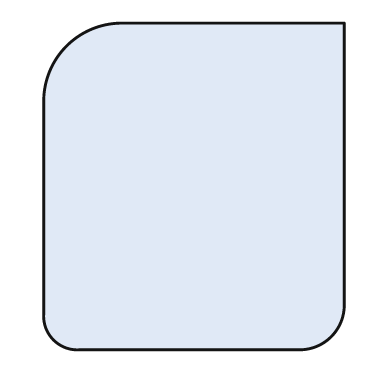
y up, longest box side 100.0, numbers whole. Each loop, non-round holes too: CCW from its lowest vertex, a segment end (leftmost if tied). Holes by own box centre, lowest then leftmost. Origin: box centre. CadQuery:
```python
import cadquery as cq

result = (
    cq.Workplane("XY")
    .moveTo(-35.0, -50.0)
    .lineTo(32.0, -50.0)
    .threePointArc((42.0, -46.0), (46.0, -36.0))
    .lineTo(46.0, 50.0)
    .lineTo(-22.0, 50.0)
    .threePointArc((-39.0, 43.0), (-46.0, 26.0))
    .lineTo(-46.0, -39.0)
    .threePointArc((-43.0, -47.0), (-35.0, -50.0))
    .close()
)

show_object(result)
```